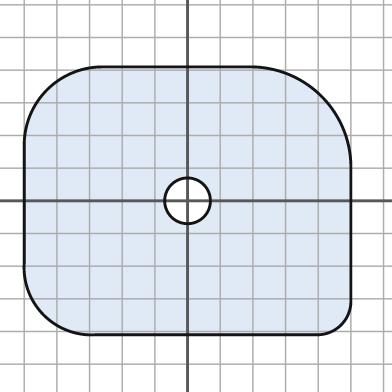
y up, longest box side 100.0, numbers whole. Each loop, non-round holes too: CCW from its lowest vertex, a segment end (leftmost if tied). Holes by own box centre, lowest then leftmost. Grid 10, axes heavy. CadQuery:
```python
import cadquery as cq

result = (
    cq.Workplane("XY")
    .moveTo(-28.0, -41.0)
    .lineTo(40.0, -41.0)
    .threePointArc((47.0, -38.0), (50.0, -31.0))
    .lineTo(50.0, 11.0)
    .threePointArc((41.0, 32.0), (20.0, 41.0))
    .lineTo(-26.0, 41.0)
    .threePointArc((-43.0, 34.0), (-50.0, 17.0))
    .lineTo(-50.0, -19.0)
    .threePointArc((-44.0, -35.0), (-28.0, -41.0))
    .close()
    .moveTo(0.0, 0.0)
    .circle(7.0)
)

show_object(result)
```